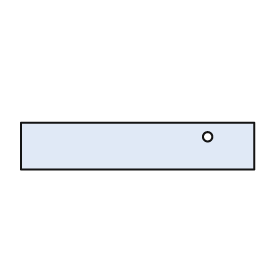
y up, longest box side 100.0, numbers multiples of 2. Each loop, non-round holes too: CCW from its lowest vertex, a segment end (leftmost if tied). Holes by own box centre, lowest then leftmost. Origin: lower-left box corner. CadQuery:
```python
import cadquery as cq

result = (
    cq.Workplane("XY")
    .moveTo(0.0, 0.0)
    .lineTo(100.0, 0.0)
    .lineTo(100.0, 20.0)
    .lineTo(0.0, 20.0)
    .close()
    .moveTo(80.0, 14.0)
    .circle(2.0)
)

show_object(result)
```